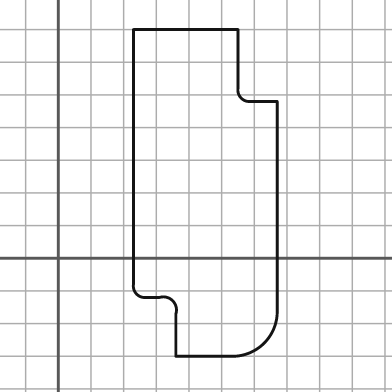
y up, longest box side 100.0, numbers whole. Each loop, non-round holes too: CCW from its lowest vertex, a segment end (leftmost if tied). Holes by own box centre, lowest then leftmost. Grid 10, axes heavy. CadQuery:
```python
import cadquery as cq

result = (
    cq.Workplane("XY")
    .moveTo(36.0, -30.0)
    .lineTo(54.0, -30.0)
    .threePointArc((63.0, -26.0), (67.0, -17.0))
    .lineTo(67.0, 48.0)
    .lineTo(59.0, 48.0)
    .threePointArc((56.0, 49.0), (55.0, 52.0))
    .lineTo(55.0, 70.0)
    .lineTo(23.0, 70.0)
    .lineTo(23.0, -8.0)
    .threePointArc((24.0, -11.0), (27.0, -12.0))
    .lineTo(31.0, -12.0)
    .threePointArc((35.0, -13.0), (36.0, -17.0))
    .close()
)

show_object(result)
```